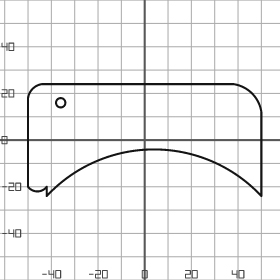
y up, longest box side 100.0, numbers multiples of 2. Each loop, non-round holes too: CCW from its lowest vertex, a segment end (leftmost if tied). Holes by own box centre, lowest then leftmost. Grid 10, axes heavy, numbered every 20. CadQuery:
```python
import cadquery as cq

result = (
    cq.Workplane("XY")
    .moveTo(-42.0, -24.0)
    .threePointArc((4.0, -4.0), (50.0, -24.0))
    .lineTo(50.0, 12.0)
    .threePointArc((46.0, 20.0), (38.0, 24.0))
    .lineTo(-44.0, 24.0)
    .threePointArc((-48.0, 22.0), (-50.0, 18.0))
    .lineTo(-50.0, -20.0)
    .threePointArc((-46.0, -22.0), (-42.0, -20.0))
    .close()
    .moveTo(-36.0, 16.0)
    .circle(2.0)
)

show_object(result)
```